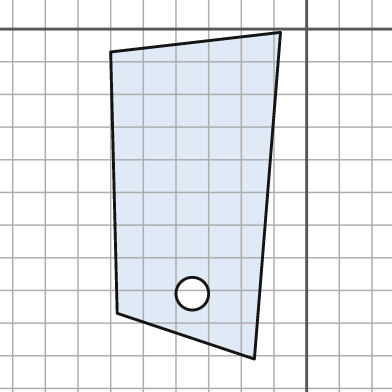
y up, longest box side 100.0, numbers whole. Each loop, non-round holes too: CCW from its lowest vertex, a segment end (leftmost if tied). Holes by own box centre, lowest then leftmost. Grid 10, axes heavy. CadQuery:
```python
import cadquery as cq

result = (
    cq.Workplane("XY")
    .moveTo(-16.0, -101.0)
    .lineTo(-8.0, -1.0)
    .lineTo(-60.0, -7.0)
    .lineTo(-58.0, -87.0)
    .close()
    .moveTo(-35.0, -81.0)
    .circle(5.0)
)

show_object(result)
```